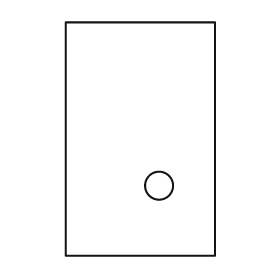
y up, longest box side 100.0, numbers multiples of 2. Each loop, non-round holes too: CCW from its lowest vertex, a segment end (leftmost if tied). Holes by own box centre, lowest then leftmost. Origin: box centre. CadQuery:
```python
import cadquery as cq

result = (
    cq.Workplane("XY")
    .moveTo(-32.0, -50.0)
    .lineTo(32.0, -50.0)
    .lineTo(32.0, 50.0)
    .lineTo(-32.0, 50.0)
    .close()
    .moveTo(8.0, -20.0)
    .circle(6.0)
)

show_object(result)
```